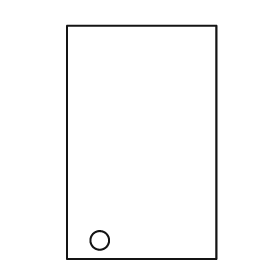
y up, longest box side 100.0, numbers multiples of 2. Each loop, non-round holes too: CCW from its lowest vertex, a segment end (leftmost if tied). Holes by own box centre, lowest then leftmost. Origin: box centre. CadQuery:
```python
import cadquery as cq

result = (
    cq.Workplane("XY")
    .moveTo(-32.0, -50.0)
    .lineTo(32.0, -50.0)
    .lineTo(32.0, 50.0)
    .lineTo(-32.0, 50.0)
    .close()
    .moveTo(-18.0, -42.0)
    .circle(4.0)
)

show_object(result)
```